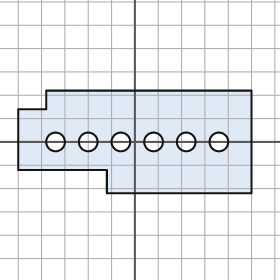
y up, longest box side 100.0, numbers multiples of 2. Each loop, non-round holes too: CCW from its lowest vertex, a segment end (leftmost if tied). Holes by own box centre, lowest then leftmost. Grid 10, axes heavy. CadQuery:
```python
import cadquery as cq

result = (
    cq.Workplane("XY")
    .moveTo(-12.0, -22.0)
    .lineTo(50.0, -22.0)
    .lineTo(50.0, 22.0)
    .lineTo(-38.0, 22.0)
    .lineTo(-38.0, 14.0)
    .lineTo(-50.0, 14.0)
    .lineTo(-50.0, -12.0)
    .lineTo(-12.0, -12.0)
    .close()
    .moveTo(-34.0, 0.0)
    .circle(4.0)
    .moveTo(-20.0, 0.0)
    .circle(4.0)
    .moveTo(-6.0, 0.0)
    .circle(4.0)
    .moveTo(8.0, 0.0)
    .circle(4.0)
    .moveTo(22.0, 0.0)
    .circle(4.0)
    .moveTo(36.0, 0.0)
    .circle(4.0)
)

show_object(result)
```